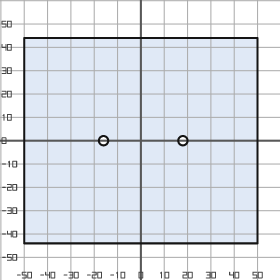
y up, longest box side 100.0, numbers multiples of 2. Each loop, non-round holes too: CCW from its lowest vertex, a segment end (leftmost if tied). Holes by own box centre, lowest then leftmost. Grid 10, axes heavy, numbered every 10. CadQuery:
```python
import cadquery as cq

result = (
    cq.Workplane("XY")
    .moveTo(-50.0, -44.0)
    .lineTo(50.0, -44.0)
    .lineTo(50.0, 44.0)
    .lineTo(-50.0, 44.0)
    .close()
    .moveTo(-16.0, 0.0)
    .circle(2.0)
    .moveTo(18.0, 0.0)
    .circle(2.0)
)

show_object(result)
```